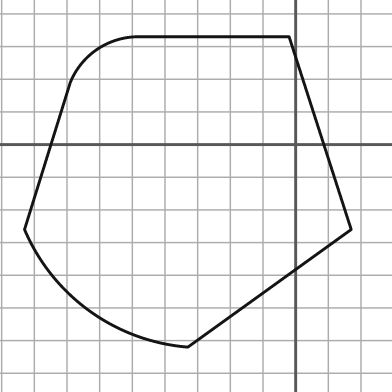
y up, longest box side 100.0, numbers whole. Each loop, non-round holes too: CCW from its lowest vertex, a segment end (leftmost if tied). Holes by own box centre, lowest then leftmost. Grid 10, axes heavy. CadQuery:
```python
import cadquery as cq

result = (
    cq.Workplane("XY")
    .moveTo(-33.0, -62.0)
    .lineTo(17.0, -26.0)
    .lineTo(-2.0, 33.0)
    .lineTo(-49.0, 33.0)
    .threePointArc((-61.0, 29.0), (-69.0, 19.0))
    .lineTo(-83.0, -26.0)
    .threePointArc((-63.0, -51.0), (-33.0, -62.0))
    .close()
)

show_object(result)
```